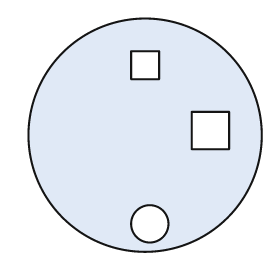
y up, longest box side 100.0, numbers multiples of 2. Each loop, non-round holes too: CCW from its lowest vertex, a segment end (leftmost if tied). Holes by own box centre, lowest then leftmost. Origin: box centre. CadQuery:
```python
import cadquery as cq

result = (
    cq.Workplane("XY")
    .moveTo(0.0, 0.0)
    .circle(50.0)
    .moveTo(2.0, -38.0)
    .circle(8.0)
    .moveTo(20.0, -6.0)
    .lineTo(36.0, -6.0)
    .lineTo(36.0, 10.0)
    .lineTo(20.0, 10.0)
    .close()
    .moveTo(-6.0, 24.0)
    .lineTo(6.0, 24.0)
    .lineTo(6.0, 36.0)
    .lineTo(-6.0, 36.0)
    .close()
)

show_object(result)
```